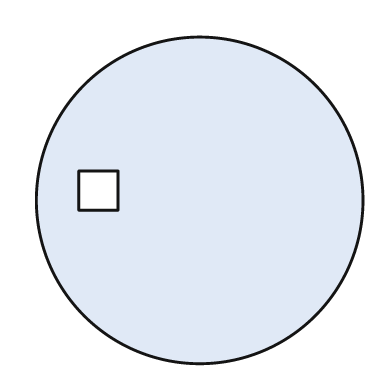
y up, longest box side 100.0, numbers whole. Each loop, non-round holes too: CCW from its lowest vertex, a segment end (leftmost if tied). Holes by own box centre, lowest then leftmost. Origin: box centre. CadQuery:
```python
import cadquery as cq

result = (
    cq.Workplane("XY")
    .moveTo(0.0, 0.0)
    .circle(50.0)
    .moveTo(-37.0, -3.0)
    .lineTo(-25.0, -3.0)
    .lineTo(-25.0, 9.0)
    .lineTo(-37.0, 9.0)
    .close()
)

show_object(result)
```